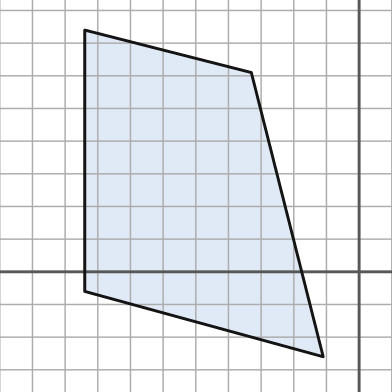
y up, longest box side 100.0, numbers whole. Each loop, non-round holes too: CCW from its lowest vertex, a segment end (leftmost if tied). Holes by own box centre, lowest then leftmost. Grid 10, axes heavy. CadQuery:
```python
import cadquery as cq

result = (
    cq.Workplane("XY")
    .moveTo(-11.0, -26.0)
    .lineTo(-33.0, 61.0)
    .lineTo(-84.0, 74.0)
    .lineTo(-84.0, -6.0)
    .close()
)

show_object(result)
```